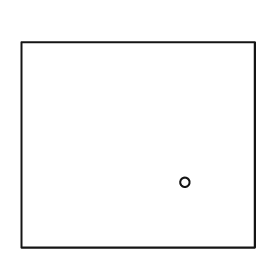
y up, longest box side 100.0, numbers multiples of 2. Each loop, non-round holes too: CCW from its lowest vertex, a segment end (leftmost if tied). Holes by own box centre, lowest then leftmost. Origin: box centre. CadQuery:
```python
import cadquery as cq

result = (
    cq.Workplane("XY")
    .moveTo(-50.0, -44.0)
    .lineTo(50.0, -44.0)
    .lineTo(50.0, 44.0)
    .lineTo(-50.0, 44.0)
    .close()
    .moveTo(20.0, -16.0)
    .circle(2.0)
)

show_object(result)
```